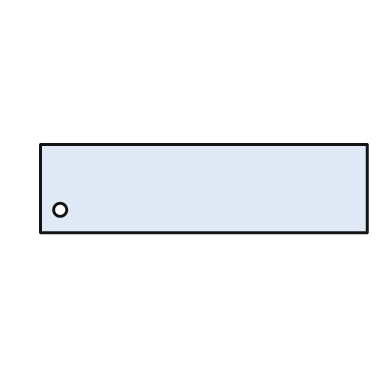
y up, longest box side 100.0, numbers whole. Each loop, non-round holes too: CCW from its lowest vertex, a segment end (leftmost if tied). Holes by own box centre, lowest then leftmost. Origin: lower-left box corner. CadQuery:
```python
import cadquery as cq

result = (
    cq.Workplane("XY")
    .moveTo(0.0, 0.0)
    .lineTo(100.0, 0.0)
    .lineTo(100.0, 27.0)
    .lineTo(0.0, 27.0)
    .close()
    .moveTo(6.0, 7.0)
    .circle(2.0)
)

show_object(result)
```